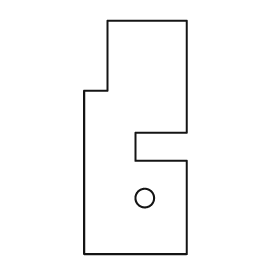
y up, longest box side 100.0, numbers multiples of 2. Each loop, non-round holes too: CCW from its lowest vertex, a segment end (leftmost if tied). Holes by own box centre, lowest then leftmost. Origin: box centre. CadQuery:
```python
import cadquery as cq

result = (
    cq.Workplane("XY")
    .moveTo(-22.0, -50.0)
    .lineTo(22.0, -50.0)
    .lineTo(22.0, -10.0)
    .lineTo(0.0, -10.0)
    .lineTo(0.0, 2.0)
    .lineTo(22.0, 2.0)
    .lineTo(22.0, 50.0)
    .lineTo(-12.0, 50.0)
    .lineTo(-12.0, 20.0)
    .lineTo(-22.0, 20.0)
    .close()
    .moveTo(4.0, -26.0)
    .circle(4.0)
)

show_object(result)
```